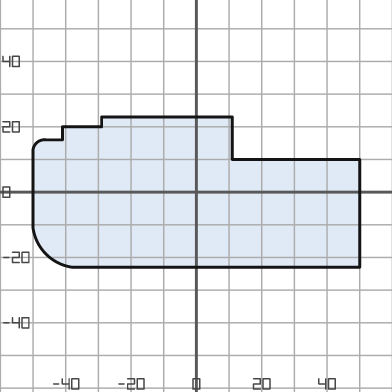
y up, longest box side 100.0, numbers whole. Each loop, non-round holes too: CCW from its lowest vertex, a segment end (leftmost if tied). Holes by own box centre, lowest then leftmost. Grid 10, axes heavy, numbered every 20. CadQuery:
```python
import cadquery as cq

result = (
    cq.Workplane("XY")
    .moveTo(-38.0, -23.0)
    .lineTo(50.0, -23.0)
    .lineTo(50.0, 10.0)
    .lineTo(11.0, 10.0)
    .lineTo(11.0, 23.0)
    .lineTo(-29.0, 23.0)
    .lineTo(-29.0, 20.0)
    .lineTo(-41.0, 20.0)
    .lineTo(-41.0, 16.0)
    .lineTo(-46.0, 16.0)
    .threePointArc((-49.0, 15.0), (-50.0, 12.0))
    .lineTo(-50.0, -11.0)
    .threePointArc((-46.0, -19.0), (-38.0, -23.0))
    .close()
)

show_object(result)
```